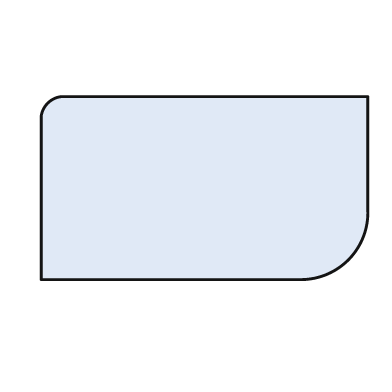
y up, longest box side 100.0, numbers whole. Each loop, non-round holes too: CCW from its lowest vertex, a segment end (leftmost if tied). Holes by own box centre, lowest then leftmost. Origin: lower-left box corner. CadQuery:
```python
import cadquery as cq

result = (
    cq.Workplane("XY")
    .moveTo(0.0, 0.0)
    .lineTo(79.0, 0.0)
    .threePointArc((94.0, 6.0), (100.0, 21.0))
    .lineTo(100.0, 56.0)
    .lineTo(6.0, 56.0)
    .threePointArc((2.0, 54.0), (0.0, 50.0))
    .close()
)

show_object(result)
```